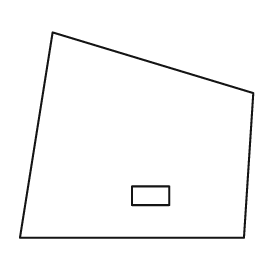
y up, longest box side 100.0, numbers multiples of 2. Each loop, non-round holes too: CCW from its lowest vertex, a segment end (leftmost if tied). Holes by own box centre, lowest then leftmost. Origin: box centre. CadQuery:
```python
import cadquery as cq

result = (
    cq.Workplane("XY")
    .moveTo(-50.0, -44.0)
    .lineTo(46.0, -44.0)
    .lineTo(50.0, 18.0)
    .lineTo(-36.0, 44.0)
    .close()
    .moveTo(-2.0, -30.0)
    .lineTo(14.0, -30.0)
    .lineTo(14.0, -22.0)
    .lineTo(-2.0, -22.0)
    .close()
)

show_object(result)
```